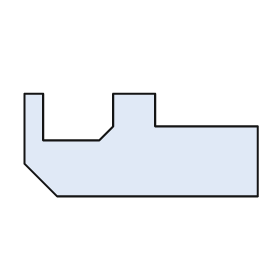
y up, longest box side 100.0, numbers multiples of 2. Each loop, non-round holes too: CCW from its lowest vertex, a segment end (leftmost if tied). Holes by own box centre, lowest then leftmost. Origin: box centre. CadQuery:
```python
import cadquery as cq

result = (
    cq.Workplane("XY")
    .moveTo(-36.0, -22.0)
    .lineTo(50.0, -22.0)
    .lineTo(50.0, 8.0)
    .lineTo(6.0, 8.0)
    .lineTo(6.0, 22.0)
    .lineTo(-12.0, 22.0)
    .lineTo(-12.0, 8.0)
    .lineTo(-18.0, 2.0)
    .lineTo(-42.0, 2.0)
    .lineTo(-42.0, 22.0)
    .lineTo(-50.0, 22.0)
    .lineTo(-50.0, -8.0)
    .close()
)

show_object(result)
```